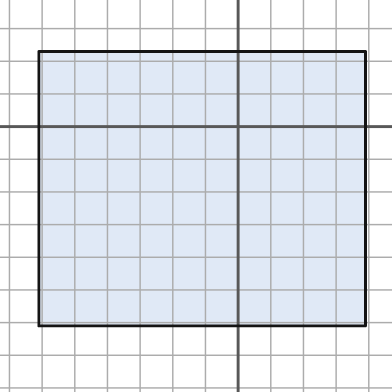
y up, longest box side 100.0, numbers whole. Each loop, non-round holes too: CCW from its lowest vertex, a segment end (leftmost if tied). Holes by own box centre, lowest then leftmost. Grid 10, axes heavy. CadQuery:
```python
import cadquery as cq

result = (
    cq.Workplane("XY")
    .moveTo(-61.0, -61.0)
    .lineTo(39.0, -61.0)
    .lineTo(39.0, 23.0)
    .lineTo(-61.0, 23.0)
    .close()
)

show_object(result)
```